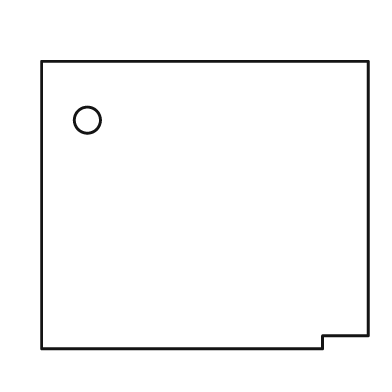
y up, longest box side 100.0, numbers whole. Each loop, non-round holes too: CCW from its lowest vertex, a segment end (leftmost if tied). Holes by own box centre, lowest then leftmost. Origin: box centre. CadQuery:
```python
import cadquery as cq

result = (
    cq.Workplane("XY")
    .moveTo(-50.0, -44.0)
    .lineTo(36.0, -44.0)
    .lineTo(36.0, -40.0)
    .lineTo(50.0, -40.0)
    .lineTo(50.0, 44.0)
    .lineTo(-50.0, 44.0)
    .close()
    .moveTo(-36.0, 26.0)
    .circle(4.0)
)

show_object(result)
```